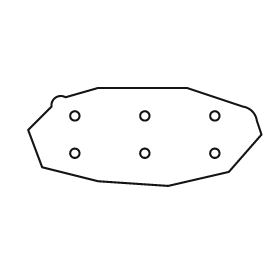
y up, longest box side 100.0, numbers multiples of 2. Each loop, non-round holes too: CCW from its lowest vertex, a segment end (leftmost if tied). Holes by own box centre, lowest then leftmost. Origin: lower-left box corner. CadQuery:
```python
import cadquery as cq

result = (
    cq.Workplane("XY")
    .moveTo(60.0, 0.0)
    .lineTo(86.0, 6.0)
    .lineTo(100.0, 22.0)
    .lineTo(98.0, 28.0)
    .threePointArc((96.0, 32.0), (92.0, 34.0))
    .lineTo(68.0, 42.0)
    .lineTo(30.0, 42.0)
    .lineTo(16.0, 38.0)
    .threePointArc((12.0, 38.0), (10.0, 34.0))
    .lineTo(0.0, 24.0)
    .lineTo(6.0, 8.0)
    .lineTo(30.0, 2.0)
    .close()
    .moveTo(20.0, 14.0)
    .circle(2.0)
    .moveTo(50.0, 14.0)
    .circle(2.0)
    .moveTo(80.0, 14.0)
    .circle(2.0)
    .moveTo(20.0, 30.0)
    .circle(2.0)
    .moveTo(50.0, 30.0)
    .circle(2.0)
    .moveTo(80.0, 30.0)
    .circle(2.0)
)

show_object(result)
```